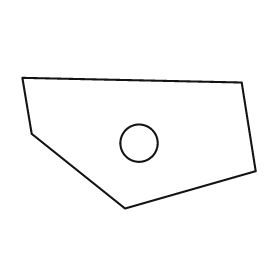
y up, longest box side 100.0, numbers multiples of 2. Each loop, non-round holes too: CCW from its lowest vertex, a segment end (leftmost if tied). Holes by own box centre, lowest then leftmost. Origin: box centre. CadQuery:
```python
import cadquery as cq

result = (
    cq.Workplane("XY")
    .moveTo(-6.0, -28.0)
    .lineTo(50.0, -12.0)
    .lineTo(44.0, 26.0)
    .lineTo(-50.0, 28.0)
    .lineTo(-46.0, 4.0)
    .close()
    .moveTo(0.0, 0.0)
    .circle(8.0)
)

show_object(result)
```